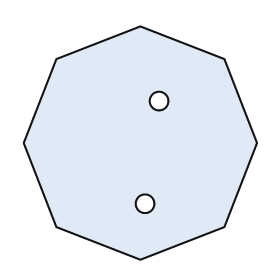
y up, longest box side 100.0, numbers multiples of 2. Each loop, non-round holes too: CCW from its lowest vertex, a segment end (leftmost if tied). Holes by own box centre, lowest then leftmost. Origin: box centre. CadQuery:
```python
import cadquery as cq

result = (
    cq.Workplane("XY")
    .moveTo(0.0, -50.0)
    .lineTo(36.0, -36.0)
    .lineTo(50.0, 0.0)
    .lineTo(36.0, 36.0)
    .lineTo(0.0, 50.0)
    .lineTo(-36.0, 36.0)
    .lineTo(-50.0, 0.0)
    .lineTo(-36.0, -36.0)
    .close()
    .moveTo(2.0, -26.0)
    .circle(4.0)
    .moveTo(8.0, 18.0)
    .circle(4.0)
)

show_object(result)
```